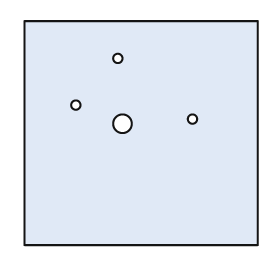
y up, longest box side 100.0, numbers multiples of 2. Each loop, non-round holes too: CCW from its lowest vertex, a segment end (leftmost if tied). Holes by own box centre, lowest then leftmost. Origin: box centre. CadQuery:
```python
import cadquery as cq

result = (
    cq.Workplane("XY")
    .moveTo(-50.0, -48.0)
    .lineTo(50.0, -48.0)
    .lineTo(50.0, 48.0)
    .lineTo(-50.0, 48.0)
    .close()
    .moveTo(-8.0, 4.0)
    .circle(4.0)
    .moveTo(22.0, 6.0)
    .circle(2.0)
    .moveTo(-28.0, 12.0)
    .circle(2.0)
    .moveTo(-10.0, 32.0)
    .circle(2.0)
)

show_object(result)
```